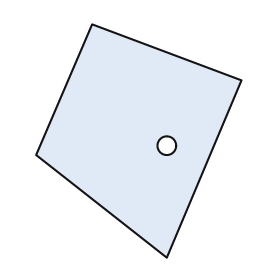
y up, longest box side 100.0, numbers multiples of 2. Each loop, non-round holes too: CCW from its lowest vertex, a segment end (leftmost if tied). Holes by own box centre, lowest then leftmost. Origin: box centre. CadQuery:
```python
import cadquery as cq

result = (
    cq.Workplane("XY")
    .moveTo(12.0, -50.0)
    .lineTo(44.0, 26.0)
    .lineTo(-20.0, 50.0)
    .lineTo(-44.0, -6.0)
    .close()
    .moveTo(12.0, -2.0)
    .circle(4.0)
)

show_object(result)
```